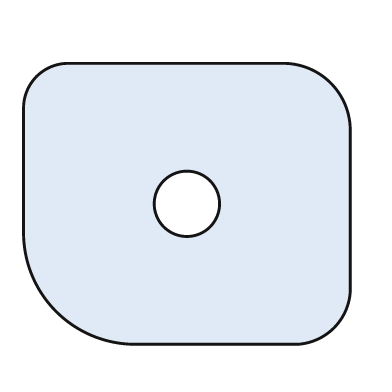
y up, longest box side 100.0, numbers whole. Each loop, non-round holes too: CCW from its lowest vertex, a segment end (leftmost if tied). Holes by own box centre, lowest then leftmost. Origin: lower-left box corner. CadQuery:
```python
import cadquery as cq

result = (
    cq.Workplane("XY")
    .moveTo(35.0, 0.0)
    .lineTo(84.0, 0.0)
    .threePointArc((95.0, 5.0), (100.0, 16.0))
    .lineTo(100.0, 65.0)
    .threePointArc((94.0, 80.0), (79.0, 86.0))
    .lineTo(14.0, 86.0)
    .threePointArc((4.0, 82.0), (0.0, 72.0))
    .lineTo(0.0, 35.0)
    .threePointArc((10.0, 10.0), (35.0, 0.0))
    .close()
    .moveTo(50.0, 43.0)
    .circle(10.0)
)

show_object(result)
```